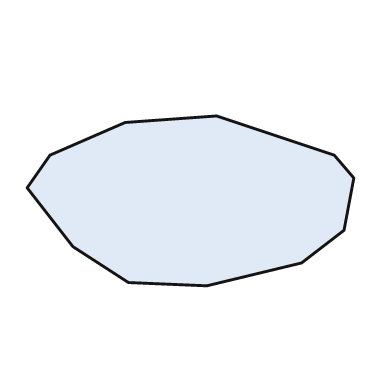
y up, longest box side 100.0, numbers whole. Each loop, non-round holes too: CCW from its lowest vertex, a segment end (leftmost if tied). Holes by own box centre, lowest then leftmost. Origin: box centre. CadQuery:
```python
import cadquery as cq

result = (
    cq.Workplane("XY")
    .moveTo(5.0, -26.0)
    .lineTo(34.0, -19.0)
    .lineTo(47.0, -9.0)
    .lineTo(50.0, 7.0)
    .lineTo(44.0, 14.0)
    .lineTo(8.0, 26.0)
    .lineTo(-20.0, 24.0)
    .lineTo(-43.0, 14.0)
    .lineTo(-50.0, 4.0)
    .lineTo(-36.0, -14.0)
    .lineTo(-19.0, -25.0)
    .close()
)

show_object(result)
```